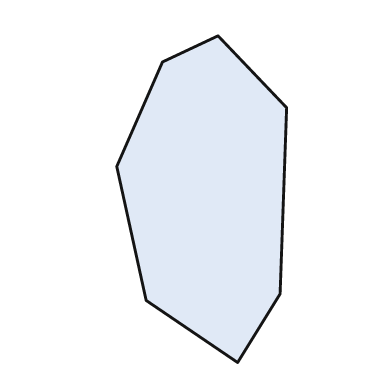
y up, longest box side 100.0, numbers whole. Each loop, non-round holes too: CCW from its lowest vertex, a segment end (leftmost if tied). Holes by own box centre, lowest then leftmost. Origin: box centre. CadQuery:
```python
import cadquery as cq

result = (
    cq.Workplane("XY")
    .moveTo(11.0, -50.0)
    .lineTo(24.0, -29.0)
    .lineTo(26.0, 28.0)
    .lineTo(5.0, 50.0)
    .lineTo(-12.0, 42.0)
    .lineTo(-26.0, 10.0)
    .lineTo(-17.0, -31.0)
    .close()
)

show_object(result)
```